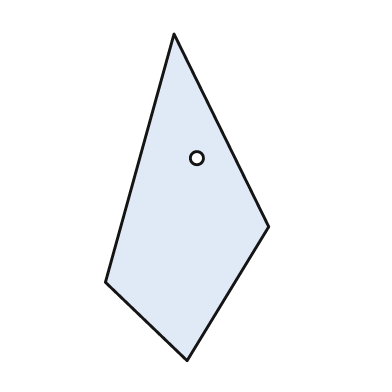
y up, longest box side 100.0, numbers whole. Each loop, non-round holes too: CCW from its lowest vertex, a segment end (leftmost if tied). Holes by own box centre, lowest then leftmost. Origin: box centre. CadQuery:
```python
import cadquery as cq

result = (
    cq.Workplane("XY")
    .moveTo(0.0, -50.0)
    .lineTo(25.0, -9.0)
    .lineTo(-4.0, 50.0)
    .lineTo(-25.0, -26.0)
    .close()
    .moveTo(3.0, 12.0)
    .circle(2.0)
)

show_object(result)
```